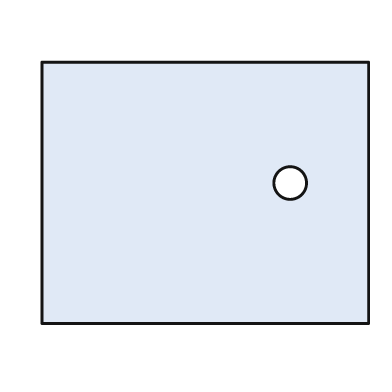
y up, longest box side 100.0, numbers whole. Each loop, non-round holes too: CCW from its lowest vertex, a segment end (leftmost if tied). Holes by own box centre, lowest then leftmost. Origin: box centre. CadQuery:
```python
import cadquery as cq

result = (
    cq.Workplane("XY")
    .moveTo(-50.0, -40.0)
    .lineTo(50.0, -40.0)
    .lineTo(50.0, 40.0)
    .lineTo(-50.0, 40.0)
    .close()
    .moveTo(26.0, 3.0)
    .circle(5.0)
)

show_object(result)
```